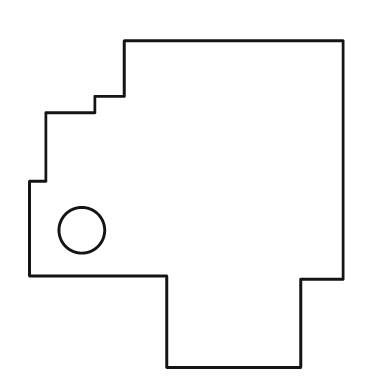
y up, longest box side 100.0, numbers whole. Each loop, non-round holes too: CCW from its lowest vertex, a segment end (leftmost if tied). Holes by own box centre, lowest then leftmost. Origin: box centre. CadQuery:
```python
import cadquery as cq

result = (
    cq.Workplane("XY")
    .moveTo(-6.0, -50.0)
    .lineTo(35.0, -50.0)
    .lineTo(35.0, -23.0)
    .lineTo(48.0, -23.0)
    .lineTo(48.0, 50.0)
    .lineTo(-19.0, 50.0)
    .lineTo(-19.0, 33.0)
    .lineTo(-28.0, 33.0)
    .lineTo(-28.0, 28.0)
    .lineTo(-43.0, 28.0)
    .lineTo(-43.0, 7.0)
    .lineTo(-48.0, 7.0)
    .lineTo(-48.0, -22.0)
    .lineTo(-6.0, -22.0)
    .close()
    .moveTo(-32.0, -8.0)
    .circle(7.0)
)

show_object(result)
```